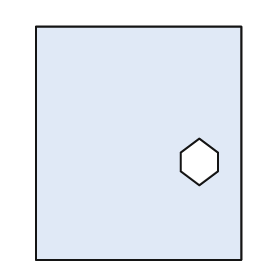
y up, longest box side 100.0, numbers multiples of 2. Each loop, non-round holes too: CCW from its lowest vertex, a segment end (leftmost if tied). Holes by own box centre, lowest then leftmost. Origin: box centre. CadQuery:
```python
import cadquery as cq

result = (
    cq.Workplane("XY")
    .moveTo(-44.0, -50.0)
    .lineTo(44.0, -50.0)
    .lineTo(44.0, 50.0)
    .lineTo(-44.0, 50.0)
    .close()
    .moveTo(26.0, -18.0)
    .lineTo(34.0, -12.0)
    .lineTo(34.0, -4.0)
    .lineTo(26.0, 2.0)
    .lineTo(18.0, -4.0)
    .lineTo(18.0, -12.0)
    .close()
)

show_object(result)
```